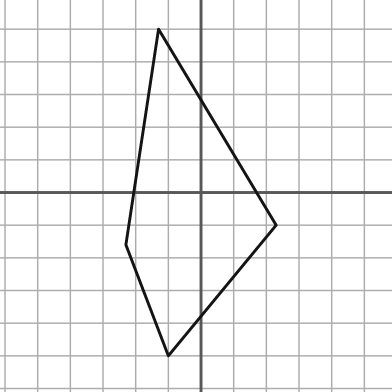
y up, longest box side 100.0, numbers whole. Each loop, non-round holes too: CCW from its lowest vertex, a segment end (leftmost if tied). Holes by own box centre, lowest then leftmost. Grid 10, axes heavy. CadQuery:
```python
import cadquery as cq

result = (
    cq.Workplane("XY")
    .moveTo(-10.0, -50.0)
    .lineTo(23.0, -10.0)
    .lineTo(-13.0, 50.0)
    .lineTo(-23.0, -16.0)
    .close()
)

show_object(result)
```